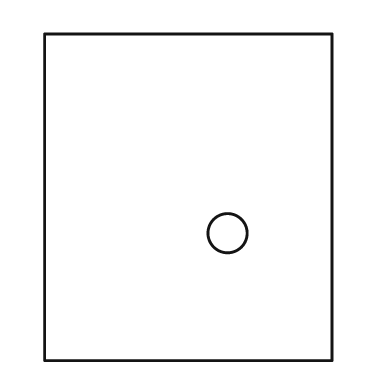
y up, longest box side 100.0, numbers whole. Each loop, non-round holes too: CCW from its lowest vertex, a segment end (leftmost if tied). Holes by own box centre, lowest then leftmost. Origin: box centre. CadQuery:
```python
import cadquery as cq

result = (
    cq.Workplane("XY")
    .moveTo(-44.0, -50.0)
    .lineTo(44.0, -50.0)
    .lineTo(44.0, 50.0)
    .lineTo(-44.0, 50.0)
    .close()
    .moveTo(12.0, -11.0)
    .circle(6.0)
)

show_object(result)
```